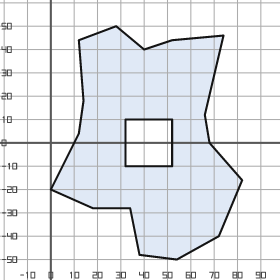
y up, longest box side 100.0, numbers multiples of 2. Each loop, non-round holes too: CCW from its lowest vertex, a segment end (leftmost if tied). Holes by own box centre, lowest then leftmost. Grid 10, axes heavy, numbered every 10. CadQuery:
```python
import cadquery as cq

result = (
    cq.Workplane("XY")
    .moveTo(54.0, -50.0)
    .lineTo(72.0, -40.0)
    .lineTo(82.0, -16.0)
    .lineTo(68.0, 0.0)
    .lineTo(66.0, 12.0)
    .lineTo(74.0, 46.0)
    .lineTo(52.0, 44.0)
    .lineTo(40.0, 40.0)
    .lineTo(28.0, 50.0)
    .lineTo(12.0, 44.0)
    .lineTo(14.0, 18.0)
    .lineTo(12.0, 4.0)
    .lineTo(0.0, -20.0)
    .lineTo(18.0, -28.0)
    .lineTo(34.0, -28.0)
    .lineTo(38.0, -48.0)
    .close()
    .moveTo(32.0, -10.0)
    .lineTo(52.0, -10.0)
    .lineTo(52.0, 10.0)
    .lineTo(32.0, 10.0)
    .close()
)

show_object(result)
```